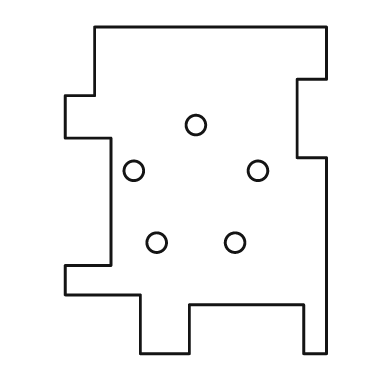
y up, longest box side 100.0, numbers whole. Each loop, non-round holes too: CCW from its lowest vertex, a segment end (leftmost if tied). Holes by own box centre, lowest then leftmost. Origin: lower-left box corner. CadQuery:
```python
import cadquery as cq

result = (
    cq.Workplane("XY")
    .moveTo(23.0, 0.0)
    .lineTo(38.0, 0.0)
    .lineTo(38.0, 15.0)
    .lineTo(73.0, 15.0)
    .lineTo(73.0, 0.0)
    .lineTo(80.0, 0.0)
    .lineTo(80.0, 60.0)
    .lineTo(71.0, 60.0)
    .lineTo(71.0, 84.0)
    .lineTo(80.0, 84.0)
    .lineTo(80.0, 100.0)
    .lineTo(9.0, 100.0)
    .lineTo(9.0, 79.0)
    .lineTo(0.0, 79.0)
    .lineTo(0.0, 66.0)
    .lineTo(14.0, 66.0)
    .lineTo(14.0, 27.0)
    .lineTo(0.0, 27.0)
    .lineTo(0.0, 18.0)
    .lineTo(23.0, 18.0)
    .close()
    .moveTo(28.0, 34.0)
    .circle(3.0)
    .moveTo(52.0, 34.0)
    .circle(3.0)
    .moveTo(21.0, 56.0)
    .circle(3.0)
    .moveTo(59.0, 56.0)
    .circle(3.0)
    .moveTo(40.0, 70.0)
    .circle(3.0)
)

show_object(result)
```